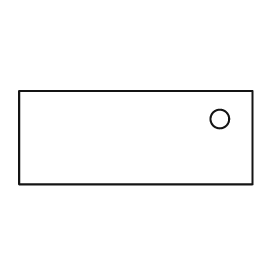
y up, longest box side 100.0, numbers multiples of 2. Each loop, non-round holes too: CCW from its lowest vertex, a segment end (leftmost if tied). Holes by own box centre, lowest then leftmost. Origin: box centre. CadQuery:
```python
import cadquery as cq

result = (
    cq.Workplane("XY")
    .moveTo(-50.0, -20.0)
    .lineTo(50.0, -20.0)
    .lineTo(50.0, 20.0)
    .lineTo(-50.0, 20.0)
    .close()
    .moveTo(36.0, 8.0)
    .circle(4.0)
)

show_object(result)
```